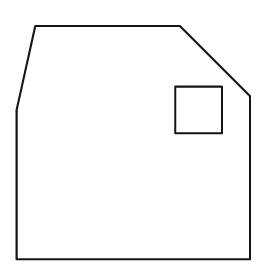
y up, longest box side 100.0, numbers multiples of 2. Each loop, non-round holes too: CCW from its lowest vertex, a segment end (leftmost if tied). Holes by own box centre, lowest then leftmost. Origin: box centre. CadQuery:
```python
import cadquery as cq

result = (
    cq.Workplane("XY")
    .moveTo(-50.0, -50.0)
    .lineTo(50.0, -50.0)
    .lineTo(50.0, 20.0)
    .lineTo(20.0, 50.0)
    .lineTo(-42.0, 50.0)
    .lineTo(-50.0, 14.0)
    .close()
    .moveTo(18.0, 4.0)
    .lineTo(38.0, 4.0)
    .lineTo(38.0, 24.0)
    .lineTo(18.0, 24.0)
    .close()
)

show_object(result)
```